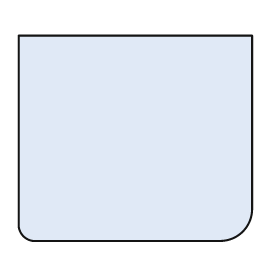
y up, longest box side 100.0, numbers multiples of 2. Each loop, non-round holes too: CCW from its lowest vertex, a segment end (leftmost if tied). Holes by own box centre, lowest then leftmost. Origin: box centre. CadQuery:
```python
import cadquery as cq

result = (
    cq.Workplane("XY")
    .moveTo(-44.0, -44.0)
    .lineTo(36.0, -44.0)
    .threePointArc((46.0, -40.0), (50.0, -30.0))
    .lineTo(50.0, 44.0)
    .lineTo(-50.0, 44.0)
    .lineTo(-50.0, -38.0)
    .threePointArc((-48.0, -42.0), (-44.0, -44.0))
    .close()
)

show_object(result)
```